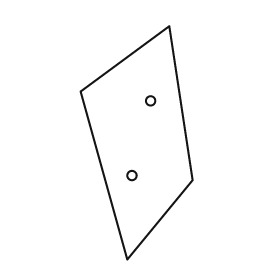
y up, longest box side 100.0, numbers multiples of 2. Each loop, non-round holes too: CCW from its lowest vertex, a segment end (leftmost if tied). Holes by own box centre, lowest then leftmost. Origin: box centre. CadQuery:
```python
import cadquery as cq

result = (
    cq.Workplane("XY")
    .moveTo(-4.0, -50.0)
    .lineTo(24.0, -16.0)
    .lineTo(14.0, 50.0)
    .lineTo(-24.0, 22.0)
    .close()
    .moveTo(-2.0, -14.0)
    .circle(2.0)
    .moveTo(6.0, 18.0)
    .circle(2.0)
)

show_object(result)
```